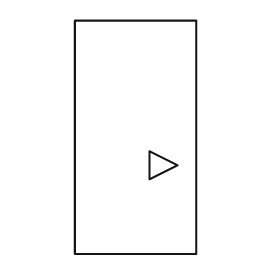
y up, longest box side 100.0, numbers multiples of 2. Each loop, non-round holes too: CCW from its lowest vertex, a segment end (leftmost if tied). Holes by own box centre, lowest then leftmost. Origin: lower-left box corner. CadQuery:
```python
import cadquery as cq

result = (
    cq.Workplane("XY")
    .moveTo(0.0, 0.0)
    .lineTo(52.0, 0.0)
    .lineTo(52.0, 100.0)
    .lineTo(0.0, 100.0)
    .close()
    .moveTo(32.0, 32.0)
    .lineTo(44.0, 38.0)
    .lineTo(32.0, 44.0)
    .close()
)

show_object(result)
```